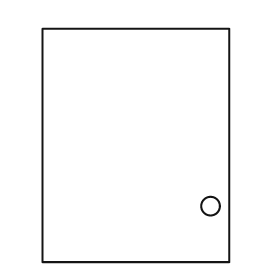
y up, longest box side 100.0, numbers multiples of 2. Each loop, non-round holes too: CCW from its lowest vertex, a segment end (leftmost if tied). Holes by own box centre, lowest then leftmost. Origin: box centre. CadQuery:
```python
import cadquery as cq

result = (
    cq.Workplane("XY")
    .moveTo(-40.0, -50.0)
    .lineTo(40.0, -50.0)
    .lineTo(40.0, 50.0)
    .lineTo(-40.0, 50.0)
    .close()
    .moveTo(32.0, -26.0)
    .circle(4.0)
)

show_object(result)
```